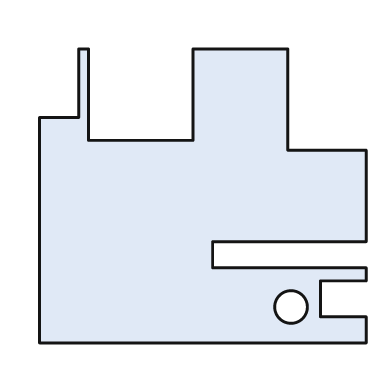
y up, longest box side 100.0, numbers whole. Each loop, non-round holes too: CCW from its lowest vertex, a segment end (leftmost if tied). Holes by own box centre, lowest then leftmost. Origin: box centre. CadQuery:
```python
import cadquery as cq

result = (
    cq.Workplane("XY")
    .moveTo(-50.0, -45.0)
    .lineTo(50.0, -45.0)
    .lineTo(50.0, -37.0)
    .lineTo(36.0, -37.0)
    .lineTo(36.0, -26.0)
    .lineTo(50.0, -26.0)
    .lineTo(50.0, -22.0)
    .lineTo(3.0, -22.0)
    .lineTo(3.0, -14.0)
    .lineTo(50.0, -14.0)
    .lineTo(50.0, 14.0)
    .lineTo(26.0, 14.0)
    .lineTo(26.0, 45.0)
    .lineTo(-3.0, 45.0)
    .lineTo(-3.0, 17.0)
    .lineTo(-35.0, 17.0)
    .lineTo(-35.0, 45.0)
    .lineTo(-38.0, 45.0)
    .lineTo(-38.0, 24.0)
    .lineTo(-50.0, 24.0)
    .close()
    .moveTo(27.0, -34.0)
    .circle(5.0)
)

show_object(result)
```